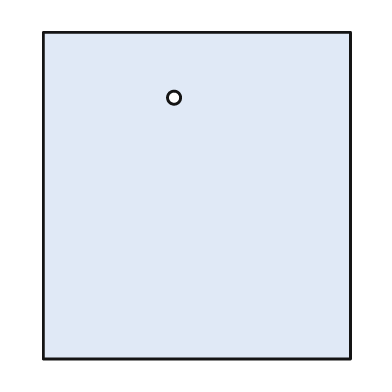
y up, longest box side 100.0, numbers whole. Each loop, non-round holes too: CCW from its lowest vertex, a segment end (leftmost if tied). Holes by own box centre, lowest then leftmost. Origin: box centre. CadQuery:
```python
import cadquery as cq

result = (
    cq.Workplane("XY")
    .moveTo(-47.0, -50.0)
    .lineTo(47.0, -50.0)
    .lineTo(47.0, 50.0)
    .lineTo(-47.0, 50.0)
    .close()
    .moveTo(-7.0, 30.0)
    .circle(2.0)
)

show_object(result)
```